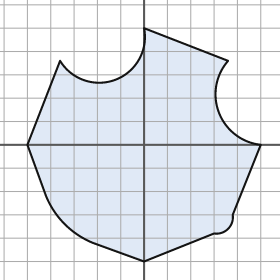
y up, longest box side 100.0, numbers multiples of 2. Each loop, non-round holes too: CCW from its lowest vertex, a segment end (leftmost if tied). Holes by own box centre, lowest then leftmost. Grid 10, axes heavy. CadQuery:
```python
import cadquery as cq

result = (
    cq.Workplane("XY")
    .moveTo(0.0, -50.0)
    .lineTo(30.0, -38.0)
    .threePointArc((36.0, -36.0), (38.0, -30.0))
    .lineTo(50.0, 0.0)
    .threePointArc((32.0, 14.0), (36.0, 36.0))
    .lineTo(0.0, 50.0)
    .threePointArc((-12.0, 28.0), (-36.0, 36.0))
    .lineTo(-50.0, 0.0)
    .lineTo(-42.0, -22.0)
    .threePointArc((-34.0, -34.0), (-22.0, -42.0))
    .close()
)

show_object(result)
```